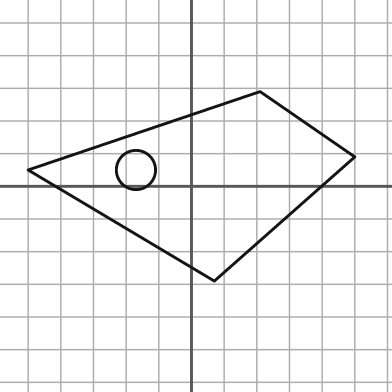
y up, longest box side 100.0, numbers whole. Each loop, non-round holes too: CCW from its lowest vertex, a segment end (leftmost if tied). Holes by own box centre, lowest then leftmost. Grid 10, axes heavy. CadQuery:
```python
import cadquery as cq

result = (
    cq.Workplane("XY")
    .moveTo(7.0, -29.0)
    .lineTo(50.0, 9.0)
    .lineTo(21.0, 29.0)
    .lineTo(-50.0, 5.0)
    .close()
    .moveTo(-17.0, 5.0)
    .circle(6.0)
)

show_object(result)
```